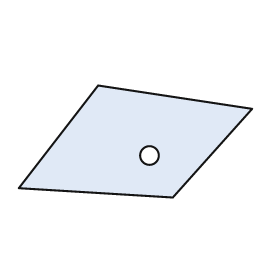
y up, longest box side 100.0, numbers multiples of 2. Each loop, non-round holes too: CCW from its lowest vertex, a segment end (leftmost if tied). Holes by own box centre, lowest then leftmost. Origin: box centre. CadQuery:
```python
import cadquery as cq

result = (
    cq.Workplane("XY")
    .moveTo(16.0, -24.0)
    .lineTo(50.0, 14.0)
    .lineTo(-16.0, 24.0)
    .lineTo(-50.0, -20.0)
    .close()
    .moveTo(6.0, -6.0)
    .circle(4.0)
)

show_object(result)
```